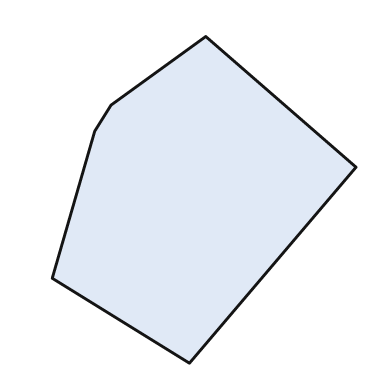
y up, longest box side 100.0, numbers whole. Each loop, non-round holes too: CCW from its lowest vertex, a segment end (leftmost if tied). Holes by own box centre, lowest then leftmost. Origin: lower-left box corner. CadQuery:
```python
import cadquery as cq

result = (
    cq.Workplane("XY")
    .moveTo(42.0, 0.0)
    .lineTo(93.0, 60.0)
    .lineTo(47.0, 100.0)
    .lineTo(18.0, 79.0)
    .lineTo(13.0, 71.0)
    .lineTo(0.0, 26.0)
    .close()
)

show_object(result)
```